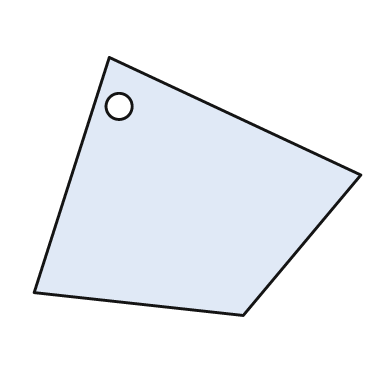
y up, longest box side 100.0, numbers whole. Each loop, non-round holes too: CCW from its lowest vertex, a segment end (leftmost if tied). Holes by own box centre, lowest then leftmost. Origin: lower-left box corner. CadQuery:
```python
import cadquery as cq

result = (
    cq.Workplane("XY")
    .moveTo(64.0, 0.0)
    .lineTo(100.0, 43.0)
    .lineTo(23.0, 79.0)
    .lineTo(0.0, 7.0)
    .close()
    .moveTo(26.0, 64.0)
    .circle(4.0)
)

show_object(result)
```